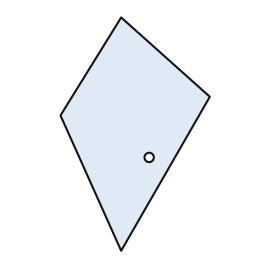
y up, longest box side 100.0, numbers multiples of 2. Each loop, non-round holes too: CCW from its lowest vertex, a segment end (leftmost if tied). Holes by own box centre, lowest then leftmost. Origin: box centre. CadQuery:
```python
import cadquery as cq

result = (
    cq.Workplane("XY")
    .moveTo(-6.0, -50.0)
    .lineTo(32.0, 16.0)
    .lineTo(-6.0, 50.0)
    .lineTo(-32.0, 8.0)
    .close()
    .moveTo(6.0, -10.0)
    .circle(2.0)
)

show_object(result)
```